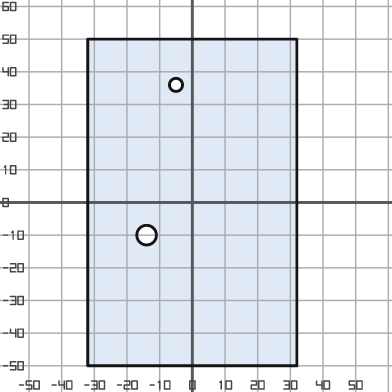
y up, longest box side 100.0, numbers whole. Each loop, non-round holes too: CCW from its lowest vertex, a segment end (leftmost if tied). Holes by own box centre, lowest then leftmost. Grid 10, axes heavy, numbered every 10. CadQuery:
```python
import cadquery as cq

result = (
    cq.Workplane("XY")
    .moveTo(-32.0, -50.0)
    .lineTo(32.0, -50.0)
    .lineTo(32.0, 50.0)
    .lineTo(-32.0, 50.0)
    .close()
    .moveTo(-14.0, -10.0)
    .circle(3.0)
    .moveTo(-5.0, 36.0)
    .circle(2.0)
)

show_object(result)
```